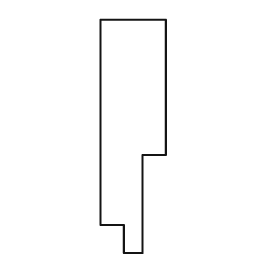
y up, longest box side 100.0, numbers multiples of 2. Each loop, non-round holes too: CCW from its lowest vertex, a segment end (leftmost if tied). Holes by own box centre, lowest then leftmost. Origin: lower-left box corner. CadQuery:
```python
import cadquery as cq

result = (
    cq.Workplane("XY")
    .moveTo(10.0, 0.0)
    .lineTo(18.0, 0.0)
    .lineTo(18.0, 42.0)
    .lineTo(28.0, 42.0)
    .lineTo(28.0, 100.0)
    .lineTo(0.0, 100.0)
    .lineTo(0.0, 12.0)
    .lineTo(10.0, 12.0)
    .close()
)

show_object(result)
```